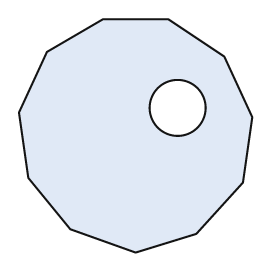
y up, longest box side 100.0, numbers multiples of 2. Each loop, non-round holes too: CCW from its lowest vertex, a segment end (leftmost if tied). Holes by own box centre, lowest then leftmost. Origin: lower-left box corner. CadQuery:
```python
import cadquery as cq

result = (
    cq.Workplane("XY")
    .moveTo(50.0, 0.0)
    .lineTo(76.0, 8.0)
    .lineTo(96.0, 30.0)
    .lineTo(100.0, 58.0)
    .lineTo(88.0, 84.0)
    .lineTo(64.0, 100.0)
    .lineTo(36.0, 100.0)
    .lineTo(12.0, 86.0)
    .lineTo(0.0, 60.0)
    .lineTo(4.0, 32.0)
    .lineTo(22.0, 10.0)
    .close()
    .moveTo(68.0, 62.0)
    .circle(12.0)
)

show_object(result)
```